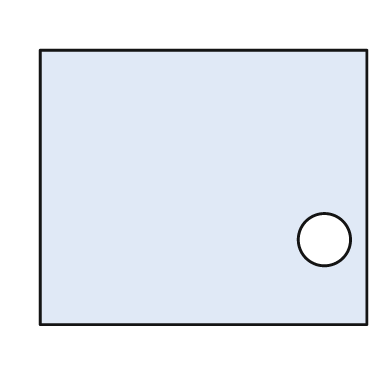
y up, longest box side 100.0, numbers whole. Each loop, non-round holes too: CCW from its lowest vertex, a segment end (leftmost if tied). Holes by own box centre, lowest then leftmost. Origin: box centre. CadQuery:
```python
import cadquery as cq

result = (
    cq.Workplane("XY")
    .moveTo(-50.0, -42.0)
    .lineTo(50.0, -42.0)
    .lineTo(50.0, 42.0)
    .lineTo(-50.0, 42.0)
    .close()
    .moveTo(37.0, -16.0)
    .circle(8.0)
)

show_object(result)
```